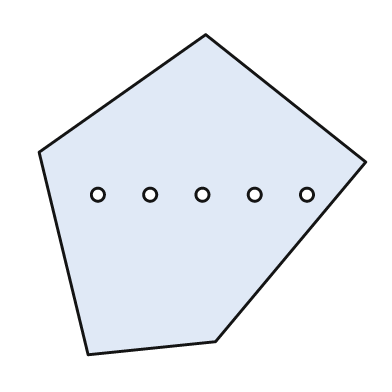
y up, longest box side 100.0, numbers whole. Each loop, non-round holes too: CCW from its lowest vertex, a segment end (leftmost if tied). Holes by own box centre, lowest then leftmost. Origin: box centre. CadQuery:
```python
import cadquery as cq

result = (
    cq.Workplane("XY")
    .moveTo(-35.0, -49.0)
    .lineTo(4.0, -45.0)
    .lineTo(50.0, 10.0)
    .lineTo(1.0, 49.0)
    .lineTo(-50.0, 13.0)
    .close()
    .moveTo(-32.0, 0.0)
    .circle(2.0)
    .moveTo(-16.0, 0.0)
    .circle(2.0)
    .moveTo(0.0, 0.0)
    .circle(2.0)
    .moveTo(16.0, 0.0)
    .circle(2.0)
    .moveTo(32.0, 0.0)
    .circle(2.0)
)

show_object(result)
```